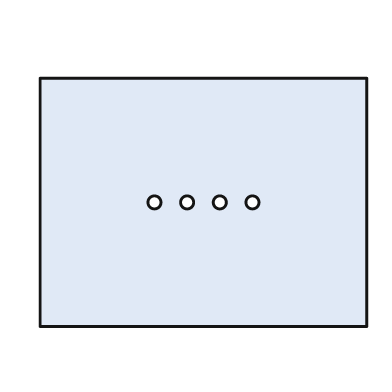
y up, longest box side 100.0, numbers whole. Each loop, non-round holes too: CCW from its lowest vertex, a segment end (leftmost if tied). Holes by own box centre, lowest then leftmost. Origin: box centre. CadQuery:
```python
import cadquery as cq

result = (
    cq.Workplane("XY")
    .moveTo(-50.0, -38.0)
    .lineTo(50.0, -38.0)
    .lineTo(50.0, 38.0)
    .lineTo(-50.0, 38.0)
    .close()
    .moveTo(-15.0, 0.0)
    .circle(2.0)
    .moveTo(-5.0, 0.0)
    .circle(2.0)
    .moveTo(5.0, 0.0)
    .circle(2.0)
    .moveTo(15.0, 0.0)
    .circle(2.0)
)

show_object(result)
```